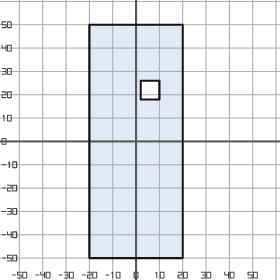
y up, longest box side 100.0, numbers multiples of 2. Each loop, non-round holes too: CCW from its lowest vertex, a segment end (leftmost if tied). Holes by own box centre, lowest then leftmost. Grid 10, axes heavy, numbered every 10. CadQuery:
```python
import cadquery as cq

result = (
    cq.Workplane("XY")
    .moveTo(-20.0, -50.0)
    .lineTo(20.0, -50.0)
    .lineTo(20.0, 50.0)
    .lineTo(-20.0, 50.0)
    .close()
    .moveTo(2.0, 18.0)
    .lineTo(10.0, 18.0)
    .lineTo(10.0, 26.0)
    .lineTo(2.0, 26.0)
    .close()
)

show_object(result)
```